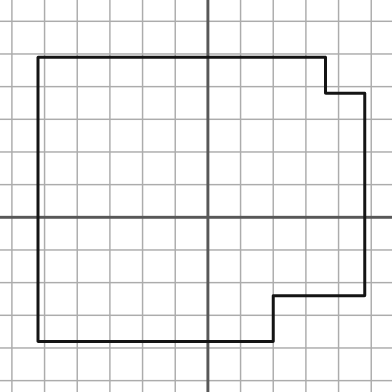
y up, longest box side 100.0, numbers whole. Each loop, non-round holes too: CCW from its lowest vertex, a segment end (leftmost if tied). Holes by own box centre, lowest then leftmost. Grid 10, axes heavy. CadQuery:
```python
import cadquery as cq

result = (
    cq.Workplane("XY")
    .moveTo(-52.0, -38.0)
    .lineTo(20.0, -38.0)
    .lineTo(20.0, -24.0)
    .lineTo(48.0, -24.0)
    .lineTo(48.0, 38.0)
    .lineTo(36.0, 38.0)
    .lineTo(36.0, 49.0)
    .lineTo(-52.0, 49.0)
    .close()
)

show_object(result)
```